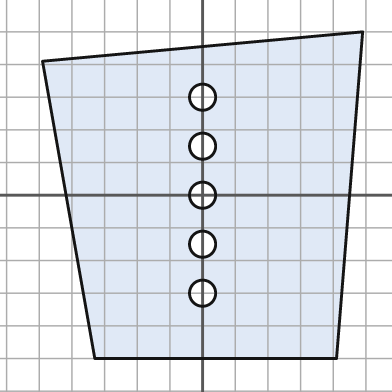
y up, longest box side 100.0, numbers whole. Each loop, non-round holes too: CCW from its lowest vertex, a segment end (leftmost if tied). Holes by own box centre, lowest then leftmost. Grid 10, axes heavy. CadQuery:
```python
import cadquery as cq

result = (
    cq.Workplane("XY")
    .moveTo(-33.0, -50.0)
    .lineTo(41.0, -50.0)
    .lineTo(49.0, 50.0)
    .lineTo(-49.0, 41.0)
    .close()
    .moveTo(0.0, -30.0)
    .circle(4.0)
    .moveTo(0.0, -15.0)
    .circle(4.0)
    .moveTo(0.0, 0.0)
    .circle(4.0)
    .moveTo(0.0, 15.0)
    .circle(4.0)
    .moveTo(0.0, 30.0)
    .circle(4.0)
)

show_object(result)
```